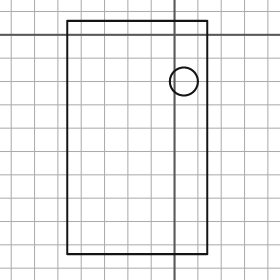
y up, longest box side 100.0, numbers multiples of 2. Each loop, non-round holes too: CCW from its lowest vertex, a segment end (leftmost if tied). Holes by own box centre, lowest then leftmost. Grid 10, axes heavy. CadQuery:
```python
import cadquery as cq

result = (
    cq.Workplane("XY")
    .moveTo(-46.0, -94.0)
    .lineTo(14.0, -94.0)
    .lineTo(14.0, 6.0)
    .lineTo(-46.0, 6.0)
    .close()
    .moveTo(4.0, -20.0)
    .circle(6.0)
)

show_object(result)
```